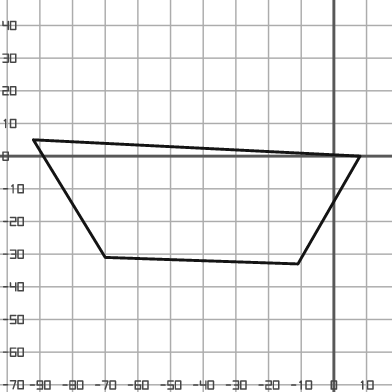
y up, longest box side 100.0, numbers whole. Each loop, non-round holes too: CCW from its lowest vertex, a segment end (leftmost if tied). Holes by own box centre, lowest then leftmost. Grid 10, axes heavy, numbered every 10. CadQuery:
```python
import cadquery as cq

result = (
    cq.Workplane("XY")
    .moveTo(-11.0, -33.0)
    .lineTo(8.0, 0.0)
    .lineTo(-92.0, 5.0)
    .lineTo(-70.0, -31.0)
    .close()
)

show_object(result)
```